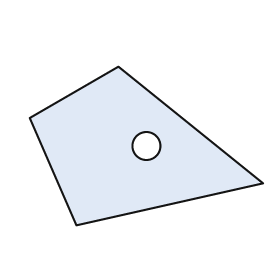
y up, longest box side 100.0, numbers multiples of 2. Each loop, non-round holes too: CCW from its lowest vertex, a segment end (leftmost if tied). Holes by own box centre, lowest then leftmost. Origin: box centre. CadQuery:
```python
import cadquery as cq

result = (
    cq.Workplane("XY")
    .moveTo(-30.0, -34.0)
    .lineTo(50.0, -16.0)
    .lineTo(-12.0, 34.0)
    .lineTo(-50.0, 12.0)
    .close()
    .moveTo(0.0, 0.0)
    .circle(6.0)
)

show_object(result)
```